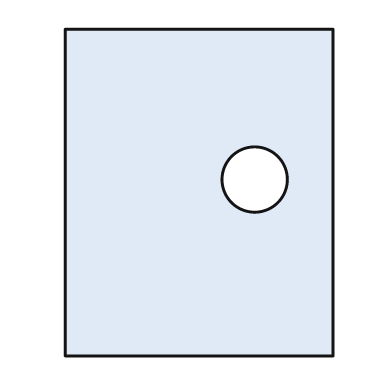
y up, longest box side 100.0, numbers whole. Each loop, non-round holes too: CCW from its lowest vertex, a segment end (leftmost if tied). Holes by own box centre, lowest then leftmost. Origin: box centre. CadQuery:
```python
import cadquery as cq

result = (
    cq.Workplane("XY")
    .moveTo(-41.0, -50.0)
    .lineTo(41.0, -50.0)
    .lineTo(41.0, 50.0)
    .lineTo(-41.0, 50.0)
    .close()
    .moveTo(17.0, 4.0)
    .circle(10.0)
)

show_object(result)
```